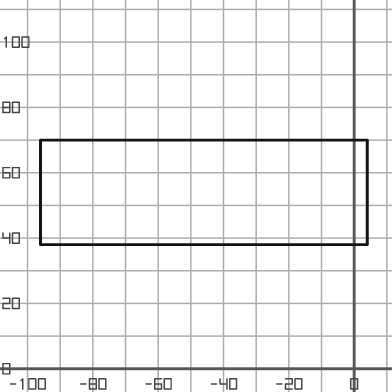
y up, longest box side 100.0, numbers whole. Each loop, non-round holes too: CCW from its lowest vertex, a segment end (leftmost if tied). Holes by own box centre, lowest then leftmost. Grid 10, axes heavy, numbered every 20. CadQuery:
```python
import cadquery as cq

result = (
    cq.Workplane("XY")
    .moveTo(-96.0, 38.0)
    .lineTo(4.0, 38.0)
    .lineTo(4.0, 70.0)
    .lineTo(-96.0, 70.0)
    .close()
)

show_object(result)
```